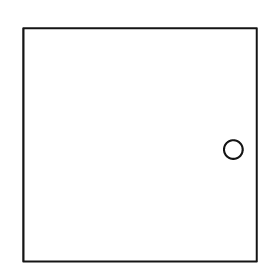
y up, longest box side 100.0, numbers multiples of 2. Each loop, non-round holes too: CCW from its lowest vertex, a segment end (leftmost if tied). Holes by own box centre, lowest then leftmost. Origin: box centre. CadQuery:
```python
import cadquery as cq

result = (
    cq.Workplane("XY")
    .moveTo(-50.0, -50.0)
    .lineTo(50.0, -50.0)
    .lineTo(50.0, 50.0)
    .lineTo(-50.0, 50.0)
    .close()
    .moveTo(40.0, -2.0)
    .circle(4.0)
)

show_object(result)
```